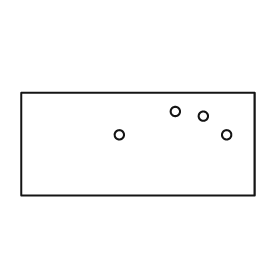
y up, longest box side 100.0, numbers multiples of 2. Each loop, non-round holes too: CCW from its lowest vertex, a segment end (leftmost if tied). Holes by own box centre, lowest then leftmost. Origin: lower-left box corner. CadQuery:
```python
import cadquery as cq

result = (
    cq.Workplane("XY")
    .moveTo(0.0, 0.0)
    .lineTo(100.0, 0.0)
    .lineTo(100.0, 44.0)
    .lineTo(0.0, 44.0)
    .close()
    .moveTo(42.0, 26.0)
    .circle(2.0)
    .moveTo(88.0, 26.0)
    .circle(2.0)
    .moveTo(78.0, 34.0)
    .circle(2.0)
    .moveTo(66.0, 36.0)
    .circle(2.0)
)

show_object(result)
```